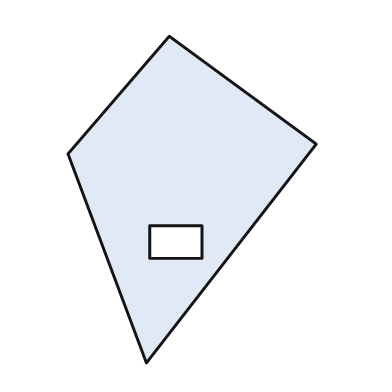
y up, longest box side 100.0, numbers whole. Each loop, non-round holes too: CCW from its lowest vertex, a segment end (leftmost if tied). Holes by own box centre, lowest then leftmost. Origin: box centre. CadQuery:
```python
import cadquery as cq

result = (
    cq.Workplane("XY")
    .moveTo(-14.0, -50.0)
    .lineTo(38.0, 17.0)
    .lineTo(-7.0, 50.0)
    .lineTo(-38.0, 14.0)
    .close()
    .moveTo(-13.0, -18.0)
    .lineTo(3.0, -18.0)
    .lineTo(3.0, -8.0)
    .lineTo(-13.0, -8.0)
    .close()
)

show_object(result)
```